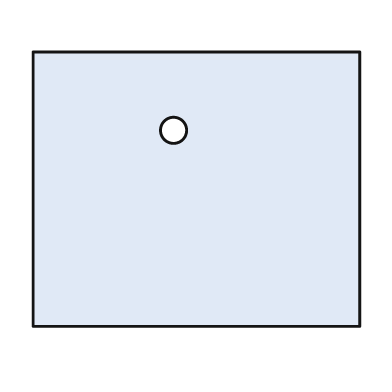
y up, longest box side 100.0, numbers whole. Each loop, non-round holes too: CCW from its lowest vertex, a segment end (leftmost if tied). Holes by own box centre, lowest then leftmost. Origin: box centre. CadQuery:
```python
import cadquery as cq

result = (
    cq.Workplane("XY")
    .moveTo(-50.0, -42.0)
    .lineTo(50.0, -42.0)
    .lineTo(50.0, 42.0)
    .lineTo(-50.0, 42.0)
    .close()
    .moveTo(-7.0, 18.0)
    .circle(4.0)
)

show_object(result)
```